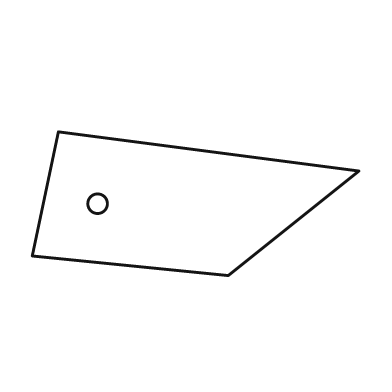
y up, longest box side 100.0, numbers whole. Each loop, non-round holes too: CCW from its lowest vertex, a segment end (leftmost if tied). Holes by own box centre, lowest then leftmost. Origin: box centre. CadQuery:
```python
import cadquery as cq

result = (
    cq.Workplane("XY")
    .moveTo(10.0, -22.0)
    .lineTo(50.0, 10.0)
    .lineTo(-42.0, 22.0)
    .lineTo(-50.0, -16.0)
    .close()
    .moveTo(-30.0, 0.0)
    .circle(3.0)
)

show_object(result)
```